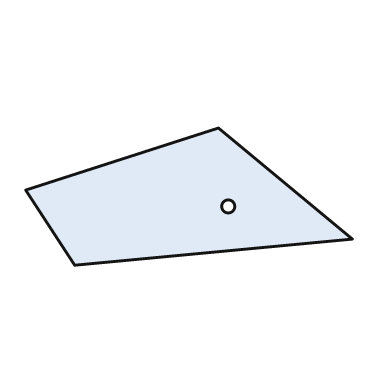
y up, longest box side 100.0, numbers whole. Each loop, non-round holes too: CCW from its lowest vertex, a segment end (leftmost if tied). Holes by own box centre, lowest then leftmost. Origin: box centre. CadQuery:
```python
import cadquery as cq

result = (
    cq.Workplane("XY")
    .moveTo(-35.0, -21.0)
    .lineTo(50.0, -13.0)
    .lineTo(9.0, 21.0)
    .lineTo(-50.0, 2.0)
    .close()
    .moveTo(12.0, -3.0)
    .circle(2.0)
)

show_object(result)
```